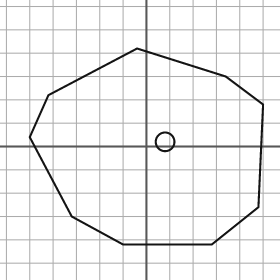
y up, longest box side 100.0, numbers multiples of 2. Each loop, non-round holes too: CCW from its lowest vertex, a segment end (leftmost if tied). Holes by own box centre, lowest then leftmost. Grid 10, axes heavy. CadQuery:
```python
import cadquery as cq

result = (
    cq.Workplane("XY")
    .moveTo(-10.0, -42.0)
    .lineTo(28.0, -42.0)
    .lineTo(48.0, -26.0)
    .lineTo(50.0, 18.0)
    .lineTo(34.0, 30.0)
    .lineTo(-4.0, 42.0)
    .lineTo(-42.0, 22.0)
    .lineTo(-50.0, 4.0)
    .lineTo(-32.0, -30.0)
    .close()
    .moveTo(8.0, 2.0)
    .circle(4.0)
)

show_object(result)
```